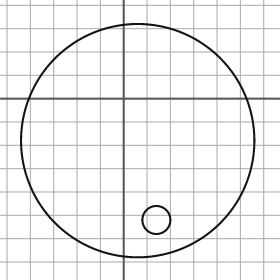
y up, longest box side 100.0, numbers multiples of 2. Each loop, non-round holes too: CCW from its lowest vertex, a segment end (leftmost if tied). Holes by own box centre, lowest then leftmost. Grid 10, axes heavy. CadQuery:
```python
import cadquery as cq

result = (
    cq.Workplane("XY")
    .moveTo(6.0, -18.0)
    .circle(50.0)
    .moveTo(14.0, -52.0)
    .circle(6.0)
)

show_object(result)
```